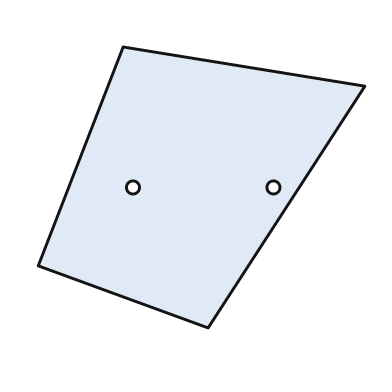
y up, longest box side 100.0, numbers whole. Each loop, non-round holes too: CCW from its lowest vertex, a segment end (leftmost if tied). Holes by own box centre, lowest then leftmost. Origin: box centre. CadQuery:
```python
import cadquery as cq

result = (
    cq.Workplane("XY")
    .moveTo(2.0, -43.0)
    .lineTo(50.0, 31.0)
    .lineTo(-24.0, 43.0)
    .lineTo(-50.0, -24.0)
    .close()
    .moveTo(-21.0, 0.0)
    .circle(2.0)
    .moveTo(22.0, 0.0)
    .circle(2.0)
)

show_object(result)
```